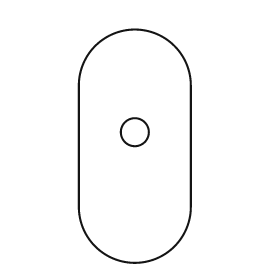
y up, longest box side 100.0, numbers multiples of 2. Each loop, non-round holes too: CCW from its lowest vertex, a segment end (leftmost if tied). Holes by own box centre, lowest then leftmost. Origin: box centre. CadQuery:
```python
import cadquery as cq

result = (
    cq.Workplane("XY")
    .moveTo(-24.0, -26.0)
    .threePointArc((0.0, -50.0), (24.0, -26.0))
    .lineTo(24.0, 26.0)
    .threePointArc((0.0, 50.0), (-24.0, 26.0))
    .close()
    .moveTo(0.0, 6.0)
    .circle(6.0)
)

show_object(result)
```